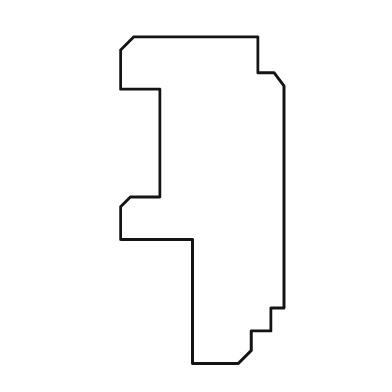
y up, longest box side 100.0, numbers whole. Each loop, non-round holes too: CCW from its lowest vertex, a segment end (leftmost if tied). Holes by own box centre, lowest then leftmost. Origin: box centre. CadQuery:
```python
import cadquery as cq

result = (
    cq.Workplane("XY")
    .moveTo(-3.0, -50.0)
    .lineTo(11.0, -50.0)
    .lineTo(15.0, -46.0)
    .lineTo(15.0, -40.0)
    .lineTo(21.0, -40.0)
    .lineTo(21.0, -33.0)
    .lineTo(25.0, -33.0)
    .lineTo(25.0, 35.0)
    .lineTo(22.0, 39.0)
    .lineTo(17.0, 39.0)
    .lineTo(17.0, 50.0)
    .lineTo(-21.0, 50.0)
    .lineTo(-25.0, 46.0)
    .lineTo(-25.0, 34.0)
    .lineTo(-13.0, 34.0)
    .lineTo(-13.0, 1.0)
    .lineTo(-22.0, 1.0)
    .lineTo(-25.0, -2.0)
    .lineTo(-25.0, -12.0)
    .lineTo(-3.0, -12.0)
    .close()
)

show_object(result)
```